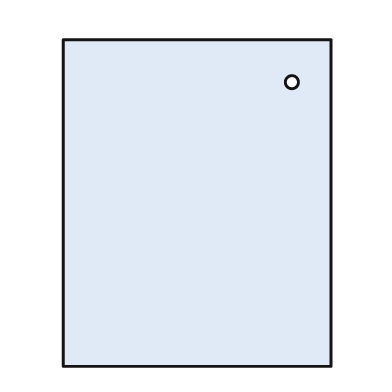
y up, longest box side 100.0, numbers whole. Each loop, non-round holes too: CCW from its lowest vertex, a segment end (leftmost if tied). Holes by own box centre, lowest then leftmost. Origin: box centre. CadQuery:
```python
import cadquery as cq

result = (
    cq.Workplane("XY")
    .moveTo(-41.0, -50.0)
    .lineTo(41.0, -50.0)
    .lineTo(41.0, 50.0)
    .lineTo(-41.0, 50.0)
    .close()
    .moveTo(29.0, 37.0)
    .circle(2.0)
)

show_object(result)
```